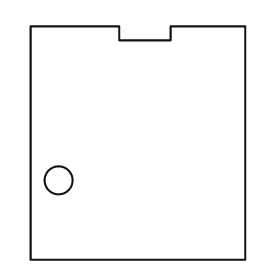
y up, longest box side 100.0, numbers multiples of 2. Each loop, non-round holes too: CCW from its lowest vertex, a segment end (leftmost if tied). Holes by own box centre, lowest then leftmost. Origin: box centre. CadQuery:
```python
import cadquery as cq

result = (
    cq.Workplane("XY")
    .moveTo(-46.0, -50.0)
    .lineTo(46.0, -50.0)
    .lineTo(46.0, 50.0)
    .lineTo(14.0, 50.0)
    .lineTo(14.0, 44.0)
    .lineTo(-8.0, 44.0)
    .lineTo(-8.0, 50.0)
    .lineTo(-46.0, 50.0)
    .close()
    .moveTo(-34.0, -16.0)
    .circle(6.0)
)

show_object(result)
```